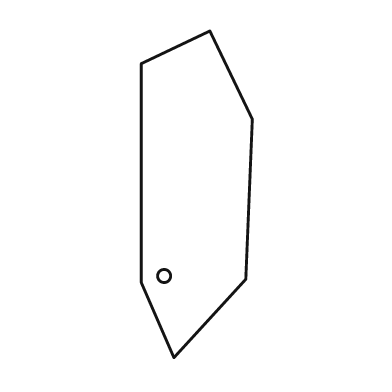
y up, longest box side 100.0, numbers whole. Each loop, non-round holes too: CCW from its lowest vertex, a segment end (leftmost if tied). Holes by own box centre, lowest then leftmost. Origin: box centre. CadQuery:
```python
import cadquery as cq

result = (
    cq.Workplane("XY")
    .moveTo(-7.0, -50.0)
    .lineTo(15.0, -26.0)
    .lineTo(17.0, 23.0)
    .lineTo(4.0, 50.0)
    .lineTo(-17.0, 40.0)
    .lineTo(-17.0, -27.0)
    .close()
    .moveTo(-10.0, -25.0)
    .circle(2.0)
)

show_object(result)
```